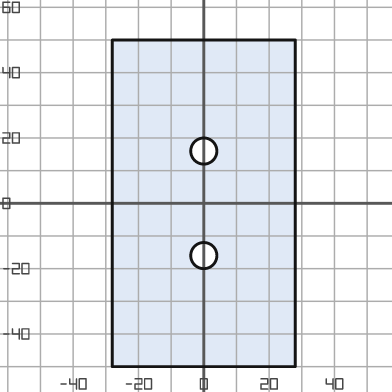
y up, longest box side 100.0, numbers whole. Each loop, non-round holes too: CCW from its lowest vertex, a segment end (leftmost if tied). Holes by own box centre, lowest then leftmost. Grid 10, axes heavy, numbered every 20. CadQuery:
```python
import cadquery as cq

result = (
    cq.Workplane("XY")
    .moveTo(-28.0, -50.0)
    .lineTo(28.0, -50.0)
    .lineTo(28.0, 50.0)
    .lineTo(-28.0, 50.0)
    .close()
    .moveTo(0.0, -16.0)
    .circle(4.0)
    .moveTo(0.0, 16.0)
    .circle(4.0)
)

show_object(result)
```